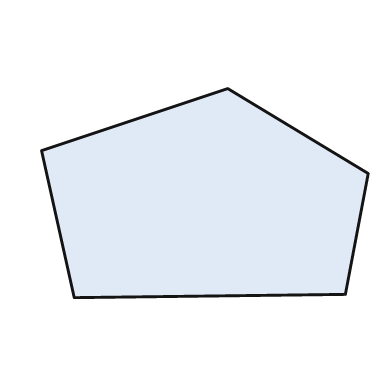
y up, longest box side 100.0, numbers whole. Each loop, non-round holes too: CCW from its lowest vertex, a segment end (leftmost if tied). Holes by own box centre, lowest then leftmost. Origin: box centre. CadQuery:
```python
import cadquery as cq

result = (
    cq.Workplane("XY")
    .moveTo(-40.0, -32.0)
    .lineTo(43.0, -31.0)
    .lineTo(50.0, 6.0)
    .lineTo(7.0, 32.0)
    .lineTo(-50.0, 13.0)
    .close()
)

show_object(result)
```